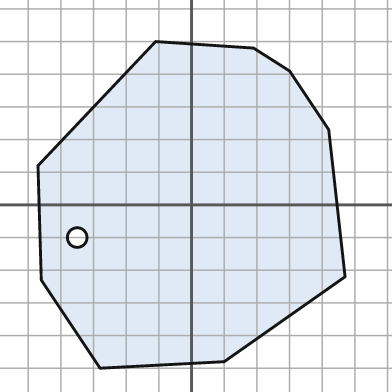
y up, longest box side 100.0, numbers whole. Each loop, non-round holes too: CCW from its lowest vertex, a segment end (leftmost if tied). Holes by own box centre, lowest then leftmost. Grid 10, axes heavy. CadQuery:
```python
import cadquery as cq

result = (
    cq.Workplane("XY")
    .moveTo(-28.0, -50.0)
    .lineTo(10.0, -48.0)
    .lineTo(47.0, -22.0)
    .lineTo(42.0, 23.0)
    .lineTo(30.0, 41.0)
    .lineTo(19.0, 48.0)
    .lineTo(-11.0, 50.0)
    .lineTo(-47.0, 12.0)
    .lineTo(-46.0, -23.0)
    .close()
    .moveTo(-35.0, -10.0)
    .circle(3.0)
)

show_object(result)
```